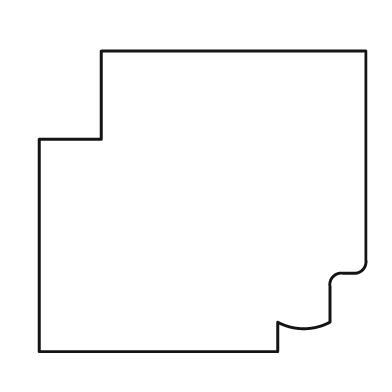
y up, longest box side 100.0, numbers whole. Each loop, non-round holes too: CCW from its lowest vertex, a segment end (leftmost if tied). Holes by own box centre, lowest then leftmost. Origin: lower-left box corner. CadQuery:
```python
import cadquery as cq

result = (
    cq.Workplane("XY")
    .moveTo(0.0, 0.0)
    .lineTo(73.0, 0.0)
    .lineTo(73.0, 9.0)
    .threePointArc((81.0, 7.0), (89.0, 9.0))
    .lineTo(89.0, 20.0)
    .threePointArc((90.0, 23.0), (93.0, 24.0))
    .lineTo(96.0, 24.0)
    .threePointArc((99.0, 25.0), (100.0, 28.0))
    .lineTo(100.0, 92.0)
    .lineTo(19.0, 92.0)
    .lineTo(19.0, 65.0)
    .lineTo(0.0, 65.0)
    .close()
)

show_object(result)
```